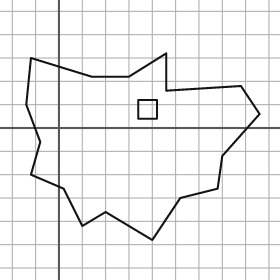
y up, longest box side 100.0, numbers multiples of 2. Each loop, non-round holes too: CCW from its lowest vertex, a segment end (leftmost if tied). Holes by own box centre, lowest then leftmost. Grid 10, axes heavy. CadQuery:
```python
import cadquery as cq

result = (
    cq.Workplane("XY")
    .moveTo(40.0, -48.0)
    .lineTo(52.0, -30.0)
    .lineTo(68.0, -26.0)
    .lineTo(70.0, -12.0)
    .lineTo(86.0, 6.0)
    .lineTo(78.0, 18.0)
    .lineTo(46.0, 16.0)
    .lineTo(46.0, 32.0)
    .lineTo(30.0, 22.0)
    .lineTo(14.0, 22.0)
    .lineTo(-12.0, 30.0)
    .lineTo(-14.0, 10.0)
    .lineTo(-8.0, -6.0)
    .lineTo(-12.0, -20.0)
    .lineTo(2.0, -26.0)
    .lineTo(10.0, -42.0)
    .lineTo(20.0, -36.0)
    .close()
    .moveTo(34.0, 4.0)
    .lineTo(42.0, 4.0)
    .lineTo(42.0, 12.0)
    .lineTo(34.0, 12.0)
    .close()
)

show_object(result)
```